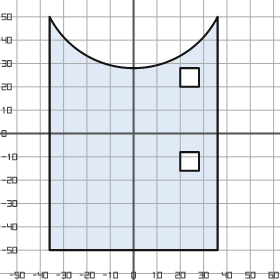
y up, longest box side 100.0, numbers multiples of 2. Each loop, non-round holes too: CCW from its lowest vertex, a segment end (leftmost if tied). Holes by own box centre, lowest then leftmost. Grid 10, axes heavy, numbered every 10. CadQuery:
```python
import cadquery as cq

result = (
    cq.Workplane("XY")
    .moveTo(-36.0, -50.0)
    .lineTo(36.0, -50.0)
    .lineTo(36.0, 50.0)
    .threePointArc((0.0, 28.0), (-36.0, 50.0))
    .close()
    .moveTo(20.0, -16.0)
    .lineTo(28.0, -16.0)
    .lineTo(28.0, -8.0)
    .lineTo(20.0, -8.0)
    .close()
    .moveTo(20.0, 20.0)
    .lineTo(28.0, 20.0)
    .lineTo(28.0, 28.0)
    .lineTo(20.0, 28.0)
    .close()
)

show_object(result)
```